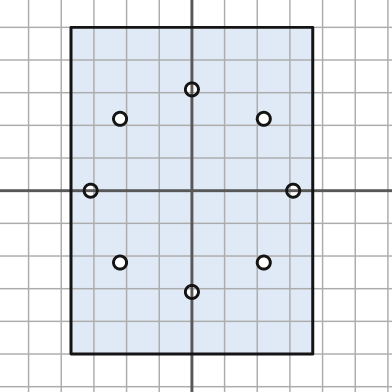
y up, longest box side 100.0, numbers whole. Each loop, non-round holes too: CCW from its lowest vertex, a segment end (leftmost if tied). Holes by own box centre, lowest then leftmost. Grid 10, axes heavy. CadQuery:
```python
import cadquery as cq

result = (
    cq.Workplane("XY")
    .moveTo(-37.0, -50.0)
    .lineTo(37.0, -50.0)
    .lineTo(37.0, 50.0)
    .lineTo(-37.0, 50.0)
    .close()
    .moveTo(0.0, -31.0)
    .circle(2.0)
    .moveTo(-22.0, -22.0)
    .circle(2.0)
    .moveTo(22.0, -22.0)
    .circle(2.0)
    .moveTo(-31.0, 0.0)
    .circle(2.0)
    .moveTo(31.0, 0.0)
    .circle(2.0)
    .moveTo(-22.0, 22.0)
    .circle(2.0)
    .moveTo(22.0, 22.0)
    .circle(2.0)
    .moveTo(0.0, 31.0)
    .circle(2.0)
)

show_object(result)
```